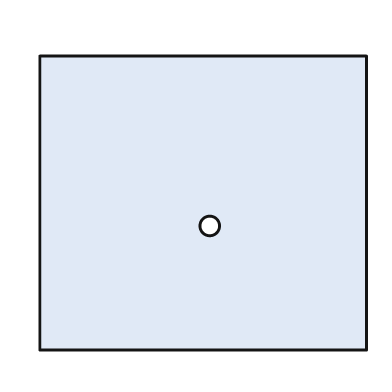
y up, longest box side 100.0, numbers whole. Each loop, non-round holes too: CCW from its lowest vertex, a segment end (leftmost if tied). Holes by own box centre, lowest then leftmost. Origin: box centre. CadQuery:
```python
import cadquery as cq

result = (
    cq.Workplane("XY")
    .moveTo(-50.0, -45.0)
    .lineTo(50.0, -45.0)
    .lineTo(50.0, 45.0)
    .lineTo(-50.0, 45.0)
    .close()
    .moveTo(2.0, -7.0)
    .circle(3.0)
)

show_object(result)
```